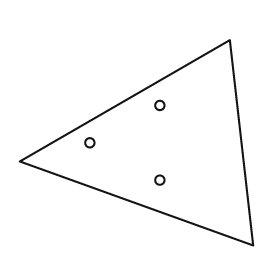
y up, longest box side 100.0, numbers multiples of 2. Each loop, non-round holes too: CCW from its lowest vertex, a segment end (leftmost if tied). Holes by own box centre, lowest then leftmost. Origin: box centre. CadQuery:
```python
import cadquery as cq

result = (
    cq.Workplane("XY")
    .moveTo(50.0, -44.0)
    .lineTo(40.0, 44.0)
    .lineTo(-50.0, -8.0)
    .close()
    .moveTo(10.0, -16.0)
    .circle(2.0)
    .moveTo(-20.0, 0.0)
    .circle(2.0)
    .moveTo(10.0, 16.0)
    .circle(2.0)
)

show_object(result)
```